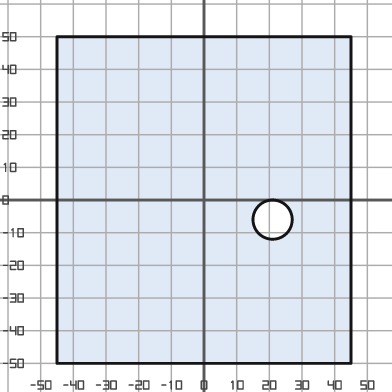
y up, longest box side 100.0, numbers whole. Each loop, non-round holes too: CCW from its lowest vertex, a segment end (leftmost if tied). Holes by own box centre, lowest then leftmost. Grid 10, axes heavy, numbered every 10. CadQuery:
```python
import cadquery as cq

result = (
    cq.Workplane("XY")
    .moveTo(-45.0, -50.0)
    .lineTo(45.0, -50.0)
    .lineTo(45.0, 50.0)
    .lineTo(-45.0, 50.0)
    .close()
    .moveTo(21.0, -6.0)
    .circle(6.0)
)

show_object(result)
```